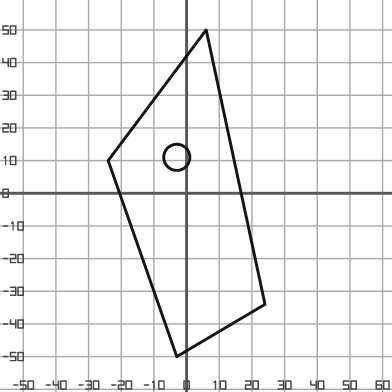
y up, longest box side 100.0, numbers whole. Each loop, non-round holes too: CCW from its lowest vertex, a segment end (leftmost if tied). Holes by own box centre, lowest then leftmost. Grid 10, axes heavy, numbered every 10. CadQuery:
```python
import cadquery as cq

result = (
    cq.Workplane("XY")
    .moveTo(-3.0, -50.0)
    .lineTo(24.0, -34.0)
    .lineTo(6.0, 50.0)
    .lineTo(-24.0, 10.0)
    .close()
    .moveTo(-3.0, 11.0)
    .circle(4.0)
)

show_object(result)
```